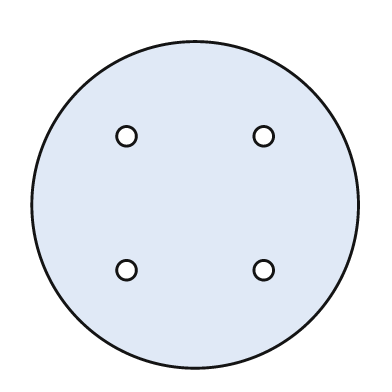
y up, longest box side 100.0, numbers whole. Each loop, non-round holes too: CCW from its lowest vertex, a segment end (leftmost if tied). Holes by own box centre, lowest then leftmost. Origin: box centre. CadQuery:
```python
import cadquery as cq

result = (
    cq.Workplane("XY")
    .moveTo(0.0, 0.0)
    .circle(50.0)
    .moveTo(-21.0, -20.0)
    .circle(3.0)
    .moveTo(21.0, -20.0)
    .circle(3.0)
    .moveTo(-21.0, 21.0)
    .circle(3.0)
    .moveTo(21.0, 21.0)
    .circle(3.0)
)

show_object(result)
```